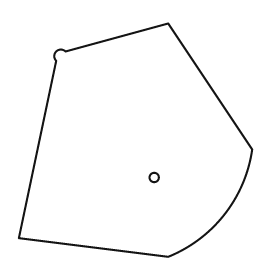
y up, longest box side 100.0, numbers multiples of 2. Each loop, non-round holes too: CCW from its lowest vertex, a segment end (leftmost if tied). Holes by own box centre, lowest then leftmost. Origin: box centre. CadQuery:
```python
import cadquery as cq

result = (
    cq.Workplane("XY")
    .moveTo(14.0, -50.0)
    .threePointArc((38.0, -32.0), (50.0, -4.0))
    .lineTo(14.0, 50.0)
    .lineTo(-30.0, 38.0)
    .threePointArc((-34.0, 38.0), (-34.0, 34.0))
    .lineTo(-50.0, -42.0)
    .close()
    .moveTo(8.0, -16.0)
    .circle(2.0)
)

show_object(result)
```